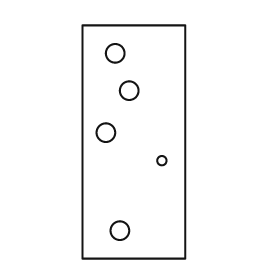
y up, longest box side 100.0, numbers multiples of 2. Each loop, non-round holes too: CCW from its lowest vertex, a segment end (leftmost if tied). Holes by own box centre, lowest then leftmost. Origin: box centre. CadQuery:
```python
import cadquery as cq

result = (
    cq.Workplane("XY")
    .moveTo(-22.0, -50.0)
    .lineTo(22.0, -50.0)
    .lineTo(22.0, 50.0)
    .lineTo(-22.0, 50.0)
    .close()
    .moveTo(-6.0, -38.0)
    .circle(4.0)
    .moveTo(12.0, -8.0)
    .circle(2.0)
    .moveTo(-12.0, 4.0)
    .circle(4.0)
    .moveTo(-2.0, 22.0)
    .circle(4.0)
    .moveTo(-8.0, 38.0)
    .circle(4.0)
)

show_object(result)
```